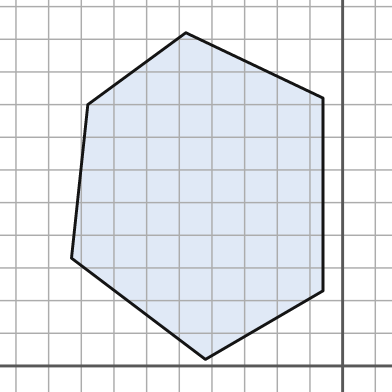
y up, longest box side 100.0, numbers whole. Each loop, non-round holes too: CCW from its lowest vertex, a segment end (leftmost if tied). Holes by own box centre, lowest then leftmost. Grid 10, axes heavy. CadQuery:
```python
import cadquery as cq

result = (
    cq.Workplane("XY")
    .moveTo(-42.0, 2.0)
    .lineTo(-6.0, 23.0)
    .lineTo(-6.0, 82.0)
    .lineTo(-48.0, 102.0)
    .lineTo(-78.0, 80.0)
    .lineTo(-83.0, 33.0)
    .close()
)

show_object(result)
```